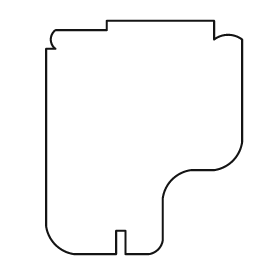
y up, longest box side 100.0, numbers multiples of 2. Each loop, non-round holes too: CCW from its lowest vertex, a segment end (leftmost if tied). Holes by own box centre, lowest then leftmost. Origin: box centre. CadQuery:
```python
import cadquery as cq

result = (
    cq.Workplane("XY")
    .moveTo(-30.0, -50.0)
    .lineTo(-12.0, -50.0)
    .lineTo(-12.0, -40.0)
    .lineTo(-8.0, -40.0)
    .lineTo(-8.0, -50.0)
    .lineTo(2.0, -50.0)
    .threePointArc((6.0, -48.0), (8.0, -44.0))
    .lineTo(8.0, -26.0)
    .threePointArc((12.0, -18.0), (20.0, -14.0))
    .lineTo(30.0, -14.0)
    .threePointArc((38.0, -10.0), (42.0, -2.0))
    .lineTo(42.0, 42.0)
    .threePointArc((36.0, 44.0), (30.0, 42.0))
    .lineTo(30.0, 50.0)
    .lineTo(-16.0, 50.0)
    .lineTo(-16.0, 46.0)
    .lineTo(-38.0, 46.0)
    .threePointArc((-40.0, 42.0), (-38.0, 38.0))
    .lineTo(-42.0, 38.0)
    .lineTo(-42.0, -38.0)
    .threePointArc((-38.0, -46.0), (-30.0, -50.0))
    .close()
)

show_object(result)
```